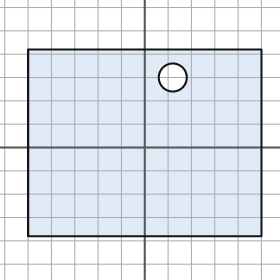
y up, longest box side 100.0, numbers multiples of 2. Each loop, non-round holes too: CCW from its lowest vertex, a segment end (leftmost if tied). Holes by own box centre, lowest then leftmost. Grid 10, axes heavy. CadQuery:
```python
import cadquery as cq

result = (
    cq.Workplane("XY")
    .moveTo(-50.0, -38.0)
    .lineTo(50.0, -38.0)
    .lineTo(50.0, 42.0)
    .lineTo(-50.0, 42.0)
    .close()
    .moveTo(12.0, 30.0)
    .circle(6.0)
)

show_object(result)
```